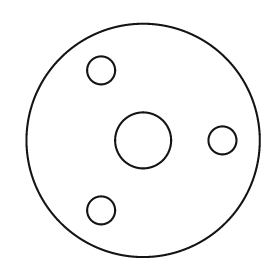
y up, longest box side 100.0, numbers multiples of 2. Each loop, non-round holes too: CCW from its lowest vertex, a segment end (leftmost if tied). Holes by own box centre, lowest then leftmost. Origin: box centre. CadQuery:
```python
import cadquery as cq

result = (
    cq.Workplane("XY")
    .moveTo(0.0, 0.0)
    .circle(50.0)
    .moveTo(-18.0, -30.0)
    .circle(6.0)
    .moveTo(0.0, 0.0)
    .circle(12.0)
    .moveTo(34.0, 0.0)
    .circle(6.0)
    .moveTo(-18.0, 30.0)
    .circle(6.0)
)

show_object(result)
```